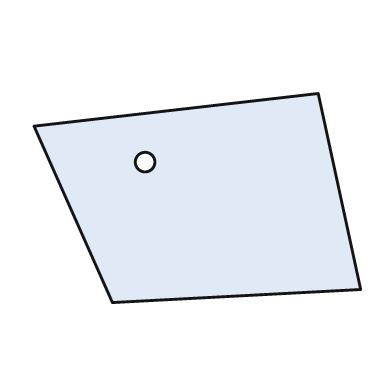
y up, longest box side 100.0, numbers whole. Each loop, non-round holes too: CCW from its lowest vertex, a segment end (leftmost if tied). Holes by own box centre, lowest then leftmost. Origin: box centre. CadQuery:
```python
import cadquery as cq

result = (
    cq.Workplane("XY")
    .moveTo(-26.0, -32.0)
    .lineTo(50.0, -28.0)
    .lineTo(37.0, 32.0)
    .lineTo(-50.0, 22.0)
    .close()
    .moveTo(-16.0, 11.0)
    .circle(3.0)
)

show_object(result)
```